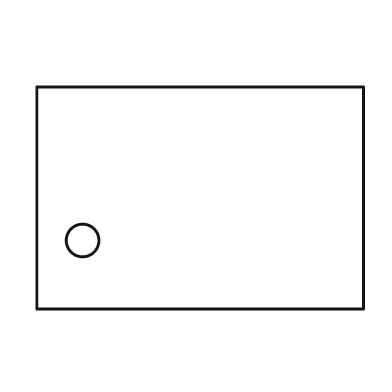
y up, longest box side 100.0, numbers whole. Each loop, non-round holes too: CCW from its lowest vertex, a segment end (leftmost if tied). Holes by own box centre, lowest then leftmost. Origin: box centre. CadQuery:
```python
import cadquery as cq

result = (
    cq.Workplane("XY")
    .moveTo(-50.0, -34.0)
    .lineTo(50.0, -34.0)
    .lineTo(50.0, 34.0)
    .lineTo(-50.0, 34.0)
    .close()
    .moveTo(-36.0, -13.0)
    .circle(5.0)
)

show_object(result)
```